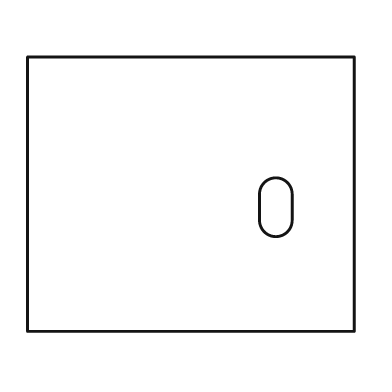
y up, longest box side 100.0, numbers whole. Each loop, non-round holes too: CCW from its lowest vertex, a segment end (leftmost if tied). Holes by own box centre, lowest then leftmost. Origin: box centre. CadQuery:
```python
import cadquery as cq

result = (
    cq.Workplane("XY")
    .moveTo(-50.0, -42.0)
    .lineTo(50.0, -42.0)
    .lineTo(50.0, 42.0)
    .lineTo(-50.0, 42.0)
    .close()
    .moveTo(21.0, -8.0)
    .threePointArc((26.0, -13.0), (31.0, -8.0))
    .lineTo(31.0, 0.0)
    .threePointArc((26.0, 5.0), (21.0, 0.0))
    .close()
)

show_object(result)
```